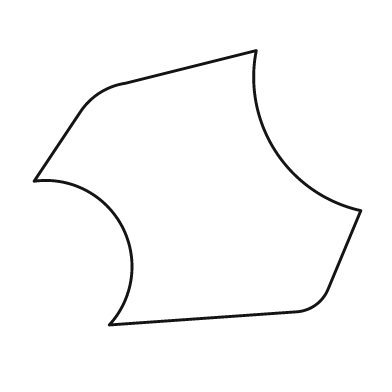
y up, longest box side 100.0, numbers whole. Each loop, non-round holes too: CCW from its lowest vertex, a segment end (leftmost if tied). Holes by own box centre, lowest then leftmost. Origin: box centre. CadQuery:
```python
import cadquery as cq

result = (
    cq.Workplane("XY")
    .moveTo(-27.0, -42.0)
    .lineTo(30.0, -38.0)
    .threePointArc((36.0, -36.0), (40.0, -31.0))
    .lineTo(50.0, -7.0)
    .threePointArc((24.0, 11.0), (18.0, 42.0))
    .lineTo(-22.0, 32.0)
    .threePointArc((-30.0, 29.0), (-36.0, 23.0))
    .lineTo(-50.0, 2.0)
    .threePointArc((-23.0, -12.0), (-27.0, -42.0))
    .close()
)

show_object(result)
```